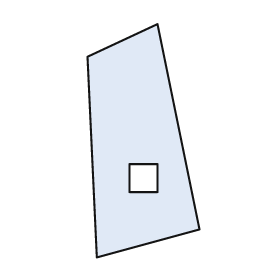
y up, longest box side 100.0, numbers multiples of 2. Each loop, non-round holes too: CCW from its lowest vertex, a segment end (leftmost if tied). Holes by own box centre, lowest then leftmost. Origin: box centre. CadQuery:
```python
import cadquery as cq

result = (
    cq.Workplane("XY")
    .moveTo(-20.0, -50.0)
    .lineTo(24.0, -38.0)
    .lineTo(6.0, 50.0)
    .lineTo(-24.0, 36.0)
    .close()
    .moveTo(-6.0, -22.0)
    .lineTo(6.0, -22.0)
    .lineTo(6.0, -10.0)
    .lineTo(-6.0, -10.0)
    .close()
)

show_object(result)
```